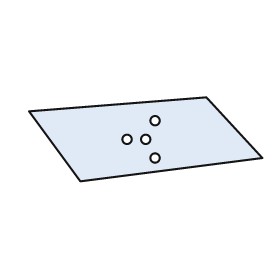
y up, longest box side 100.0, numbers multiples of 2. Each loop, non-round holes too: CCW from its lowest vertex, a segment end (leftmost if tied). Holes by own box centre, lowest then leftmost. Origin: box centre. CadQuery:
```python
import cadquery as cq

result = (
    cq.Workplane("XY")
    .moveTo(-28.0, -18.0)
    .lineTo(50.0, -8.0)
    .lineTo(26.0, 18.0)
    .lineTo(-50.0, 12.0)
    .close()
    .moveTo(4.0, -8.0)
    .circle(2.0)
    .moveTo(-8.0, 0.0)
    .circle(2.0)
    .moveTo(0.0, 0.0)
    .circle(2.0)
    .moveTo(4.0, 8.0)
    .circle(2.0)
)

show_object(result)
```